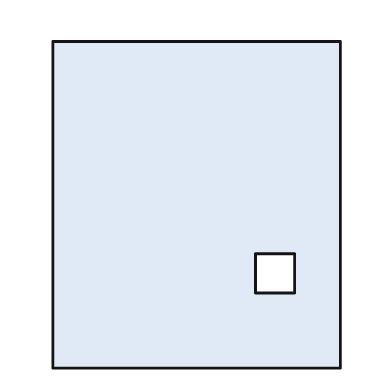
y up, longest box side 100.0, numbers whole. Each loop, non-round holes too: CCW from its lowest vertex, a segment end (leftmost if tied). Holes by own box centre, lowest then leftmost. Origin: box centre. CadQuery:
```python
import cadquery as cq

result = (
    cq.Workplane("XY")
    .moveTo(-44.0, -50.0)
    .lineTo(44.0, -50.0)
    .lineTo(44.0, 50.0)
    .lineTo(-44.0, 50.0)
    .close()
    .moveTo(18.0, -27.0)
    .lineTo(30.0, -27.0)
    .lineTo(30.0, -15.0)
    .lineTo(18.0, -15.0)
    .close()
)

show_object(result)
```